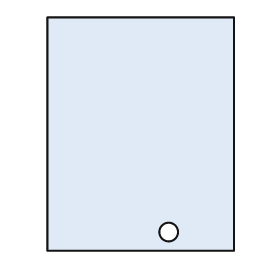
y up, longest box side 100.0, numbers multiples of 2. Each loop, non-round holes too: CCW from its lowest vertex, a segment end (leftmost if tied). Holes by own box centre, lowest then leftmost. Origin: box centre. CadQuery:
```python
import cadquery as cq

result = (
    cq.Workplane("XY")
    .moveTo(-40.0, -50.0)
    .lineTo(40.0, -50.0)
    .lineTo(40.0, 50.0)
    .lineTo(-40.0, 50.0)
    .close()
    .moveTo(12.0, -42.0)
    .circle(4.0)
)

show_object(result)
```